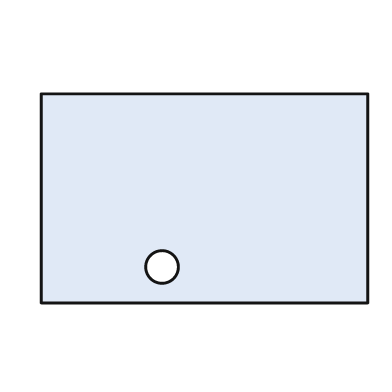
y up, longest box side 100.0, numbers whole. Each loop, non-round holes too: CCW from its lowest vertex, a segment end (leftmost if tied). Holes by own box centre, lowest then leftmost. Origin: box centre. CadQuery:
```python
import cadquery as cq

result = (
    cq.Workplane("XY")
    .moveTo(-50.0, -32.0)
    .lineTo(50.0, -32.0)
    .lineTo(50.0, 32.0)
    .lineTo(-50.0, 32.0)
    .close()
    .moveTo(-13.0, -21.0)
    .circle(5.0)
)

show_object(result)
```